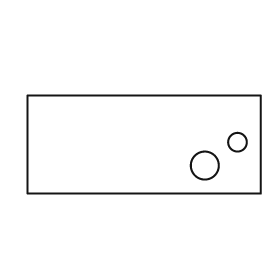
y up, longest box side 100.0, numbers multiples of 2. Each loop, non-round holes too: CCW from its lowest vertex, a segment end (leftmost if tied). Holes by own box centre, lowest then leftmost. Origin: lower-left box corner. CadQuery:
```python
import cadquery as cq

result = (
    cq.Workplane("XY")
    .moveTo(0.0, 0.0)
    .lineTo(100.0, 0.0)
    .lineTo(100.0, 42.0)
    .lineTo(0.0, 42.0)
    .close()
    .moveTo(76.0, 12.0)
    .circle(6.0)
    .moveTo(90.0, 22.0)
    .circle(4.0)
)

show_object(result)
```